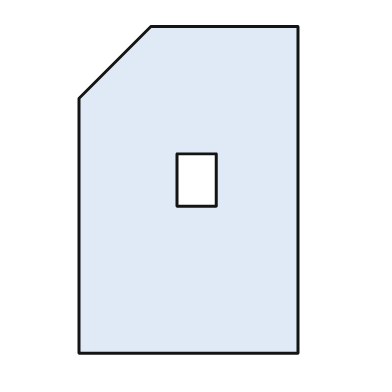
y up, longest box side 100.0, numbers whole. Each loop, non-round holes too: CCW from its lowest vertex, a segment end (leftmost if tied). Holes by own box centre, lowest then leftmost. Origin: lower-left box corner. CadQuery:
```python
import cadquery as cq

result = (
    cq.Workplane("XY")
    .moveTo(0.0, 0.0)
    .lineTo(67.0, 0.0)
    .lineTo(67.0, 100.0)
    .lineTo(22.0, 100.0)
    .lineTo(0.0, 78.0)
    .close()
    .moveTo(30.0, 45.0)
    .lineTo(42.0, 45.0)
    .lineTo(42.0, 61.0)
    .lineTo(30.0, 61.0)
    .close()
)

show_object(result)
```